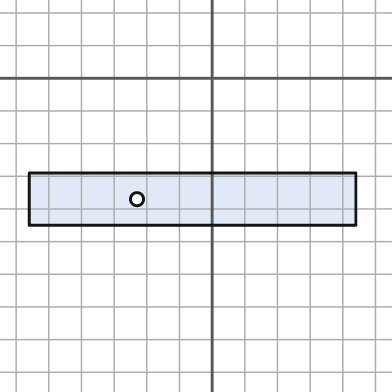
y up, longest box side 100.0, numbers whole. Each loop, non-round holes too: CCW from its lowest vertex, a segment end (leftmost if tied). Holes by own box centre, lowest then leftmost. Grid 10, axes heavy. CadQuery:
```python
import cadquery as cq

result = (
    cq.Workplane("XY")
    .moveTo(-56.0, -45.0)
    .lineTo(44.0, -45.0)
    .lineTo(44.0, -29.0)
    .lineTo(-56.0, -29.0)
    .close()
    .moveTo(-23.0, -37.0)
    .circle(2.0)
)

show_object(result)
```